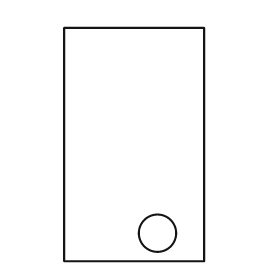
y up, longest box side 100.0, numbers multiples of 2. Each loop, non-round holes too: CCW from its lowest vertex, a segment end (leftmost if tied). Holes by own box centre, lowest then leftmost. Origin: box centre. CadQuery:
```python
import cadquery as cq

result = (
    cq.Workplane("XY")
    .moveTo(-30.0, -50.0)
    .lineTo(30.0, -50.0)
    .lineTo(30.0, 50.0)
    .lineTo(-30.0, 50.0)
    .close()
    .moveTo(10.0, -38.0)
    .circle(8.0)
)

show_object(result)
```